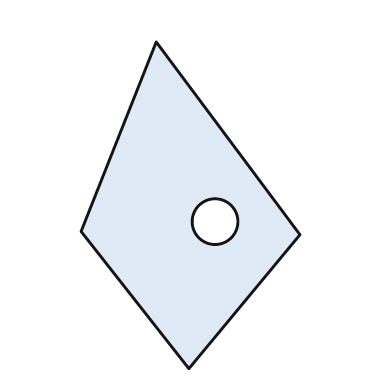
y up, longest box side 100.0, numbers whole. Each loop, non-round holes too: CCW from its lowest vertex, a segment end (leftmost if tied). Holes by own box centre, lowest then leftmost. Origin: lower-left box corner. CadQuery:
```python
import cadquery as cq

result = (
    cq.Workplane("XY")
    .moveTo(33.0, 0.0)
    .lineTo(67.0, 41.0)
    .lineTo(23.0, 100.0)
    .lineTo(0.0, 42.0)
    .close()
    .moveTo(41.0, 45.0)
    .circle(7.0)
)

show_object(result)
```